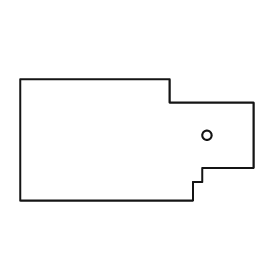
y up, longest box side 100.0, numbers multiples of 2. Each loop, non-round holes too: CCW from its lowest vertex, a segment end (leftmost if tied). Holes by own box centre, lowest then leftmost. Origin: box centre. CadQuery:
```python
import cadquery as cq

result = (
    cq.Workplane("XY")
    .moveTo(-50.0, -26.0)
    .lineTo(24.0, -26.0)
    .lineTo(24.0, -18.0)
    .lineTo(28.0, -18.0)
    .lineTo(28.0, -12.0)
    .lineTo(50.0, -12.0)
    .lineTo(50.0, 16.0)
    .lineTo(14.0, 16.0)
    .lineTo(14.0, 26.0)
    .lineTo(-50.0, 26.0)
    .close()
    .moveTo(30.0, 2.0)
    .circle(2.0)
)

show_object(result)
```